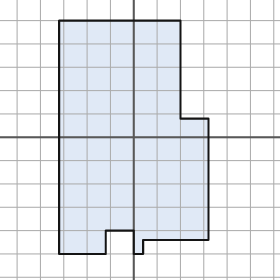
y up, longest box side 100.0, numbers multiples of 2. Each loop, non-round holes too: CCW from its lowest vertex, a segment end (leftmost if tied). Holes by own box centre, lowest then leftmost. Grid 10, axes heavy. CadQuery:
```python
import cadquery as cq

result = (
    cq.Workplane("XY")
    .moveTo(-32.0, -50.0)
    .lineTo(-12.0, -50.0)
    .lineTo(-12.0, -40.0)
    .lineTo(0.0, -40.0)
    .lineTo(0.0, -50.0)
    .lineTo(4.0, -50.0)
    .lineTo(4.0, -44.0)
    .lineTo(32.0, -44.0)
    .lineTo(32.0, 8.0)
    .lineTo(20.0, 8.0)
    .lineTo(20.0, 50.0)
    .lineTo(-32.0, 50.0)
    .close()
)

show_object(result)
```